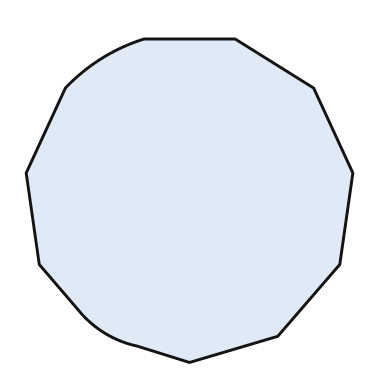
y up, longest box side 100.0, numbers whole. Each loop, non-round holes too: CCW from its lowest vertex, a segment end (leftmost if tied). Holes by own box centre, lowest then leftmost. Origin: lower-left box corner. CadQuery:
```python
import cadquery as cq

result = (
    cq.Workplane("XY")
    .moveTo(50.0, 0.0)
    .lineTo(77.0, 8.0)
    .lineTo(96.0, 30.0)
    .lineTo(100.0, 58.0)
    .lineTo(88.0, 84.0)
    .lineTo(64.0, 99.0)
    .lineTo(36.0, 99.0)
    .threePointArc((23.0, 93.0), (12.0, 84.0))
    .lineTo(0.0, 58.0)
    .lineTo(4.0, 30.0)
    .lineTo(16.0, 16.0)
    .threePointArc((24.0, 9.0), (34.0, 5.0))
    .close()
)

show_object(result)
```